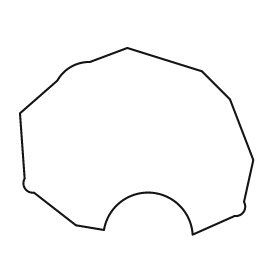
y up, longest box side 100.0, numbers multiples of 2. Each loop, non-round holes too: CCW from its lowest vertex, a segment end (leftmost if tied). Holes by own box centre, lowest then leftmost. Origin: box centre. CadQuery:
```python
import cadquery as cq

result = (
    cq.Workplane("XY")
    .moveTo(24.0, -40.0)
    .lineTo(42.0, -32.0)
    .threePointArc((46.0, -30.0), (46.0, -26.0))
    .lineTo(50.0, -8.0)
    .lineTo(40.0, 18.0)
    .lineTo(28.0, 30.0)
    .lineTo(-4.0, 40.0)
    .lineTo(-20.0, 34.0)
    .threePointArc((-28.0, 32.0), (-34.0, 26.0))
    .lineTo(-50.0, 12.0)
    .lineTo(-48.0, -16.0)
    .threePointArc((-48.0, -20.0), (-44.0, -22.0))
    .lineTo(-26.0, -36.0)
    .lineTo(-14.0, -38.0)
    .threePointArc((6.0, -22.0), (24.0, -40.0))
    .close()
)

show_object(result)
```